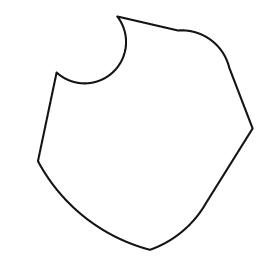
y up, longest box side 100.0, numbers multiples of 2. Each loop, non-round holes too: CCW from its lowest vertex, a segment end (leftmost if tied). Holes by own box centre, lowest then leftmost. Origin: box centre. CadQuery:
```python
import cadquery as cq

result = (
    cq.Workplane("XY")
    .moveTo(2.0, -50.0)
    .threePointArc((16.0, -42.0), (26.0, -30.0))
    .lineTo(46.0, 2.0)
    .lineTo(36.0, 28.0)
    .threePointArc((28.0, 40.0), (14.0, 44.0))
    .lineTo(-12.0, 50.0)
    .threePointArc((-14.0, 26.0), (-38.0, 26.0))
    .lineTo(-46.0, -12.0)
    .threePointArc((-26.0, -36.0), (2.0, -50.0))
    .close()
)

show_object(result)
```